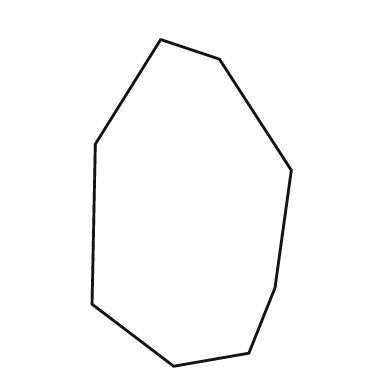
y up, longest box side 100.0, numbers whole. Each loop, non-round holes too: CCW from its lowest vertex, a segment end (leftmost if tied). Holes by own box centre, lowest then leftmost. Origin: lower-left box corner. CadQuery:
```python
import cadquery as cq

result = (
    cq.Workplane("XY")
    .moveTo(25.0, 0.0)
    .lineTo(48.0, 4.0)
    .lineTo(56.0, 24.0)
    .lineTo(61.0, 60.0)
    .lineTo(39.0, 94.0)
    .lineTo(21.0, 100.0)
    .lineTo(1.0, 68.0)
    .lineTo(0.0, 19.0)
    .close()
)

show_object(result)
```